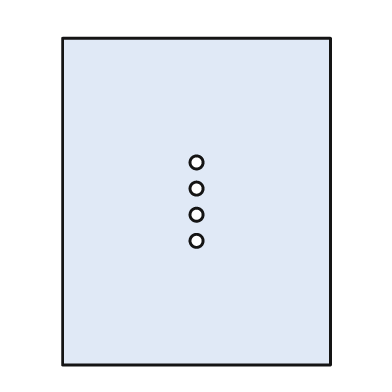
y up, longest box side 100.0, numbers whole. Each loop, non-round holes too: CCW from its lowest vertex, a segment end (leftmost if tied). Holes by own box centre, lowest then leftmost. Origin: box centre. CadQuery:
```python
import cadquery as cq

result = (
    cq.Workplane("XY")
    .moveTo(-41.0, -50.0)
    .lineTo(41.0, -50.0)
    .lineTo(41.0, 50.0)
    .lineTo(-41.0, 50.0)
    .close()
    .moveTo(0.0, -12.0)
    .circle(2.0)
    .moveTo(0.0, -4.0)
    .circle(2.0)
    .moveTo(0.0, 4.0)
    .circle(2.0)
    .moveTo(0.0, 12.0)
    .circle(2.0)
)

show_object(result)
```